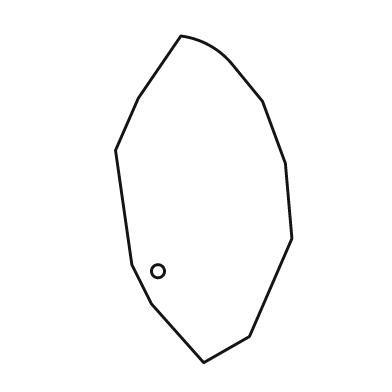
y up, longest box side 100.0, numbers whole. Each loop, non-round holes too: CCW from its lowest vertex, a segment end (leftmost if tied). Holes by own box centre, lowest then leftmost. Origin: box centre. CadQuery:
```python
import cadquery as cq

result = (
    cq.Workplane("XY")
    .moveTo(0.0, -50.0)
    .lineTo(14.0, -42.0)
    .lineTo(27.0, -12.0)
    .lineTo(25.0, 11.0)
    .lineTo(18.0, 30.0)
    .lineTo(9.0, 41.0)
    .threePointArc((2.0, 47.0), (-7.0, 50.0))
    .lineTo(-20.0, 31.0)
    .lineTo(-27.0, 15.0)
    .lineTo(-22.0, -20.0)
    .lineTo(-16.0, -32.0)
    .close()
    .moveTo(-14.0, -22.0)
    .circle(2.0)
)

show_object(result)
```